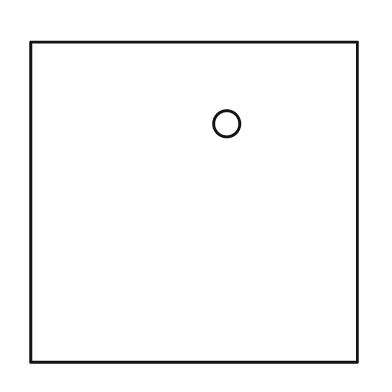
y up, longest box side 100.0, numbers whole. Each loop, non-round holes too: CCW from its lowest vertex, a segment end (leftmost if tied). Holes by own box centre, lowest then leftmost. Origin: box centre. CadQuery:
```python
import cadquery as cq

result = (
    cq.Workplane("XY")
    .moveTo(-50.0, -49.0)
    .lineTo(50.0, -49.0)
    .lineTo(50.0, 49.0)
    .lineTo(-50.0, 49.0)
    .close()
    .moveTo(10.0, 24.0)
    .circle(4.0)
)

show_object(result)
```